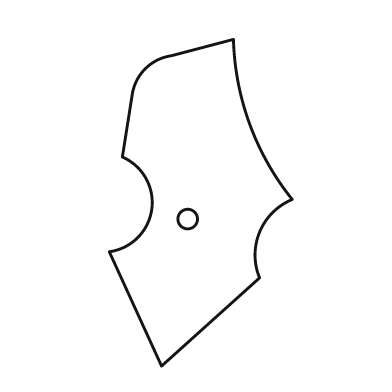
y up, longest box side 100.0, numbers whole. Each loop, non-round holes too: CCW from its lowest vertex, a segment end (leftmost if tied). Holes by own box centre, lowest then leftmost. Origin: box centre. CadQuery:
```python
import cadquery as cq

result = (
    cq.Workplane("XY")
    .moveTo(-12.0, -50.0)
    .lineTo(18.0, -23.0)
    .threePointArc((18.0, -9.0), (28.0, 1.0))
    .threePointArc((15.0, 24.0), (10.0, 50.0))
    .lineTo(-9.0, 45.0)
    .threePointArc((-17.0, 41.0), (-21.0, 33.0))
    .lineTo(-24.0, 14.0)
    .threePointArc((-15.0, -2.0), (-28.0, -15.0))
    .close()
    .moveTo(-4.0, -5.0)
    .circle(3.0)
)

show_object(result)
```